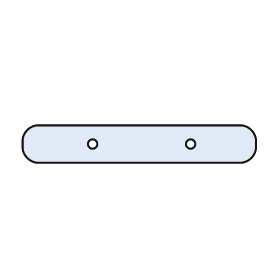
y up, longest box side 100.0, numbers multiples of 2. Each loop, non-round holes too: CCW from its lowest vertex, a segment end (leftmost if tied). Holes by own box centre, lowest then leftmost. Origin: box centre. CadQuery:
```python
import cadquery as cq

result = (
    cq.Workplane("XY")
    .moveTo(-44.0, -8.0)
    .lineTo(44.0, -8.0)
    .threePointArc((48.0, -6.0), (50.0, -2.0))
    .lineTo(50.0, 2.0)
    .threePointArc((48.0, 6.0), (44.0, 8.0))
    .lineTo(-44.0, 8.0)
    .threePointArc((-48.0, 6.0), (-50.0, 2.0))
    .lineTo(-50.0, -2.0)
    .threePointArc((-48.0, -6.0), (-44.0, -8.0))
    .close()
    .moveTo(-20.0, 0.0)
    .circle(2.0)
    .moveTo(22.0, 0.0)
    .circle(2.0)
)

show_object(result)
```